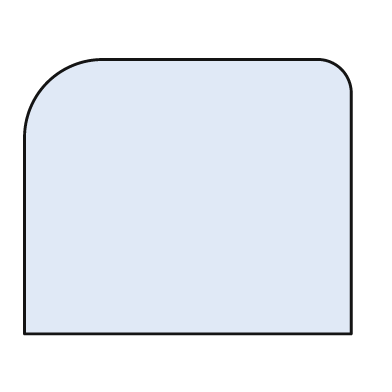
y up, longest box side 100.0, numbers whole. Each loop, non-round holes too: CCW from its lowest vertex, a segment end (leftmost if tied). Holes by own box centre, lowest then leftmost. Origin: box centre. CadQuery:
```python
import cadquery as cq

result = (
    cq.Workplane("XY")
    .moveTo(-50.0, -42.0)
    .lineTo(50.0, -42.0)
    .lineTo(50.0, 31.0)
    .threePointArc((47.0, 39.0), (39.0, 42.0))
    .lineTo(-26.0, 42.0)
    .threePointArc((-43.0, 35.0), (-50.0, 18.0))
    .close()
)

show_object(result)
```